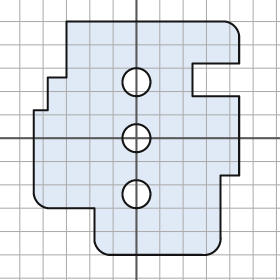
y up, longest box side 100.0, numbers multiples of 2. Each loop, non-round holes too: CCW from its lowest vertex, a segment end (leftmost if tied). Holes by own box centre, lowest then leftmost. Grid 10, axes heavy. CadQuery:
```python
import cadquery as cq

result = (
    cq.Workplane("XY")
    .moveTo(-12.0, -50.0)
    .lineTo(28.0, -50.0)
    .threePointArc((34.0, -48.0), (36.0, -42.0))
    .lineTo(36.0, -16.0)
    .lineTo(44.0, -16.0)
    .lineTo(44.0, 18.0)
    .lineTo(24.0, 18.0)
    .lineTo(24.0, 32.0)
    .lineTo(44.0, 32.0)
    .lineTo(44.0, 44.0)
    .threePointArc((42.0, 48.0), (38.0, 50.0))
    .lineTo(-30.0, 50.0)
    .lineTo(-30.0, 26.0)
    .lineTo(-38.0, 26.0)
    .lineTo(-38.0, 12.0)
    .lineTo(-44.0, 12.0)
    .lineTo(-44.0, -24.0)
    .threePointArc((-42.0, -28.0), (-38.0, -30.0))
    .lineTo(-18.0, -30.0)
    .lineTo(-18.0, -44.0)
    .threePointArc((-16.0, -48.0), (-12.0, -50.0))
    .close()
    .moveTo(0.0, -24.0)
    .circle(6.0)
    .moveTo(0.0, 0.0)
    .circle(6.0)
    .moveTo(0.0, 24.0)
    .circle(6.0)
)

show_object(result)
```